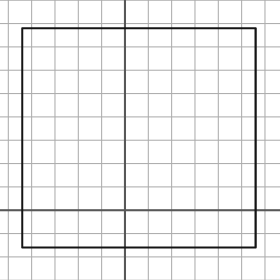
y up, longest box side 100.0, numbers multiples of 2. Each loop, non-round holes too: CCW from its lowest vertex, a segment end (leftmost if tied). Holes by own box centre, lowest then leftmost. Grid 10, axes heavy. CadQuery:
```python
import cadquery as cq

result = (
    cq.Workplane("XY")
    .moveTo(-44.0, -16.0)
    .lineTo(56.0, -16.0)
    .lineTo(56.0, 78.0)
    .lineTo(-44.0, 78.0)
    .close()
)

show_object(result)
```